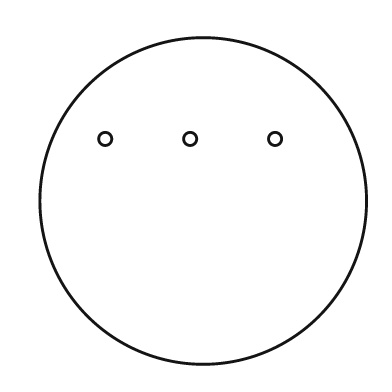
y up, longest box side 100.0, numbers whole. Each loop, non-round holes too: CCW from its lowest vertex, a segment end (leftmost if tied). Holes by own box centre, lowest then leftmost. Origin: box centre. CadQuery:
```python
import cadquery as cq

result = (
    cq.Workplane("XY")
    .moveTo(0.0, 0.0)
    .circle(50.0)
    .moveTo(-30.0, 19.0)
    .circle(2.0)
    .moveTo(-4.0, 19.0)
    .circle(2.0)
    .moveTo(22.0, 19.0)
    .circle(2.0)
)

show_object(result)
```